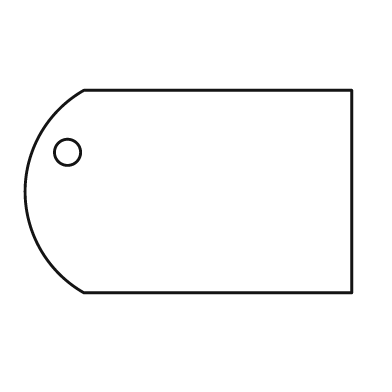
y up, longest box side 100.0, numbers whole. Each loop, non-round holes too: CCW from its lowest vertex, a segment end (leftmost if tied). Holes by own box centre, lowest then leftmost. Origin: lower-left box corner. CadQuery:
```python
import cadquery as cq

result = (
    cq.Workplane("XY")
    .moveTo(18.0, 0.0)
    .lineTo(100.0, 0.0)
    .lineTo(100.0, 62.0)
    .lineTo(18.0, 62.0)
    .threePointArc((0.0, 31.0), (18.0, 0.0))
    .close()
    .moveTo(13.0, 43.0)
    .circle(4.0)
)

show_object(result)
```